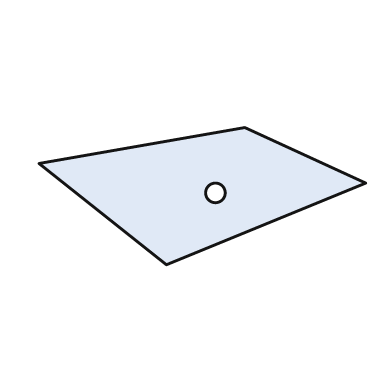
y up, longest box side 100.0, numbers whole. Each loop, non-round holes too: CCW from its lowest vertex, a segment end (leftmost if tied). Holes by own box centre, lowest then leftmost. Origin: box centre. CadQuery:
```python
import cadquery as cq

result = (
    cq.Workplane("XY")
    .moveTo(-11.0, -21.0)
    .lineTo(50.0, 4.0)
    .lineTo(13.0, 21.0)
    .lineTo(-50.0, 10.0)
    .close()
    .moveTo(4.0, 1.0)
    .circle(3.0)
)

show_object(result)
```